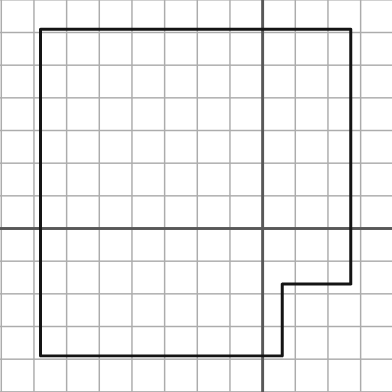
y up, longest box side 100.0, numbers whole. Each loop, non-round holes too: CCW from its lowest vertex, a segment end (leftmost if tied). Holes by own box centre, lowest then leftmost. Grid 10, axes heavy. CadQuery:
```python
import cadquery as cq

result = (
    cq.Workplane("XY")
    .moveTo(-68.0, -39.0)
    .lineTo(6.0, -39.0)
    .lineTo(6.0, -17.0)
    .lineTo(27.0, -17.0)
    .lineTo(27.0, 61.0)
    .lineTo(-68.0, 61.0)
    .close()
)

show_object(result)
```